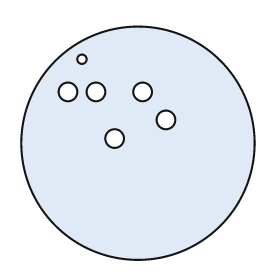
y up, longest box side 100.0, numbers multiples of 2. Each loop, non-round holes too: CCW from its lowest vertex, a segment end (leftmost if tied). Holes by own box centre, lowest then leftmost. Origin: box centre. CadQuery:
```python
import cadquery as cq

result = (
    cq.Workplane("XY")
    .moveTo(0.0, 0.0)
    .circle(50.0)
    .moveTo(-10.0, 2.0)
    .circle(4.0)
    .moveTo(12.0, 10.0)
    .circle(4.0)
    .moveTo(-30.0, 22.0)
    .circle(4.0)
    .moveTo(-18.0, 22.0)
    .circle(4.0)
    .moveTo(2.0, 22.0)
    .circle(4.0)
    .moveTo(-24.0, 36.0)
    .circle(2.0)
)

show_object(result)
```